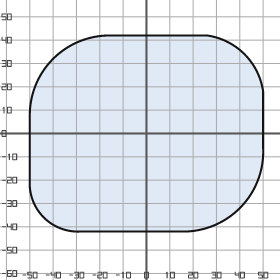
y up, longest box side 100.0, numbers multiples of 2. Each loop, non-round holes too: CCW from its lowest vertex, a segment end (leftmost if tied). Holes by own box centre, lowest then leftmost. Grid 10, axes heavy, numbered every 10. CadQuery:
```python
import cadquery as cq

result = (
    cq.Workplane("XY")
    .moveTo(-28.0, -42.0)
    .lineTo(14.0, -42.0)
    .threePointArc((40.0, -32.0), (50.0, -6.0))
    .lineTo(50.0, 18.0)
    .threePointArc((42.0, 34.0), (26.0, 42.0))
    .lineTo(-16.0, 42.0)
    .threePointArc((-40.0, 32.0), (-50.0, 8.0))
    .lineTo(-50.0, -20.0)
    .threePointArc((-44.0, -36.0), (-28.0, -42.0))
    .close()
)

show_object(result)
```